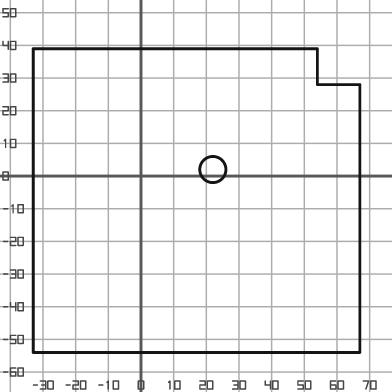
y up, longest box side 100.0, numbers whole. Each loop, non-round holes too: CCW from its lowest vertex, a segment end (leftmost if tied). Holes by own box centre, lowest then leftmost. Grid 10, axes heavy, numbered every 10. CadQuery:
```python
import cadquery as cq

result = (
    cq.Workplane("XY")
    .moveTo(-33.0, -54.0)
    .lineTo(67.0, -54.0)
    .lineTo(67.0, 28.0)
    .lineTo(54.0, 28.0)
    .lineTo(54.0, 39.0)
    .lineTo(-33.0, 39.0)
    .close()
    .moveTo(22.0, 2.0)
    .circle(4.0)
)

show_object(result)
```